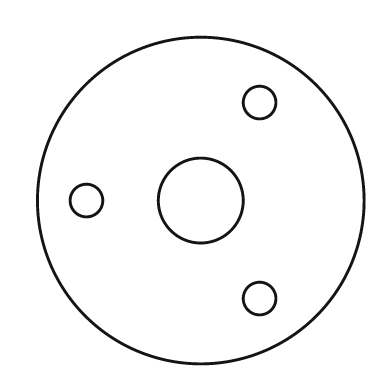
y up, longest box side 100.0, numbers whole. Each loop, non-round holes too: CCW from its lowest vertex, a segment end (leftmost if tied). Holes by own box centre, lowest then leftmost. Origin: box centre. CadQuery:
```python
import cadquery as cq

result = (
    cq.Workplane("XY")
    .moveTo(0.0, 0.0)
    .circle(50.0)
    .moveTo(18.0, -30.0)
    .circle(5.0)
    .moveTo(-35.0, 0.0)
    .circle(5.0)
    .moveTo(0.0, 0.0)
    .circle(13.0)
    .moveTo(18.0, 30.0)
    .circle(5.0)
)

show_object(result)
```